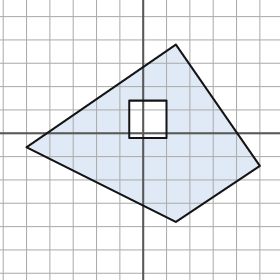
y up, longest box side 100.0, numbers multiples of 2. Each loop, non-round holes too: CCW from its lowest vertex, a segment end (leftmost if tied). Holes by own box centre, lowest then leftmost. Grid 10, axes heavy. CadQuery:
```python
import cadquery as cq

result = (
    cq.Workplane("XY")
    .moveTo(14.0, -38.0)
    .lineTo(50.0, -14.0)
    .lineTo(14.0, 38.0)
    .lineTo(-50.0, -6.0)
    .close()
    .moveTo(-6.0, -2.0)
    .lineTo(10.0, -2.0)
    .lineTo(10.0, 14.0)
    .lineTo(-6.0, 14.0)
    .close()
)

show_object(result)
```